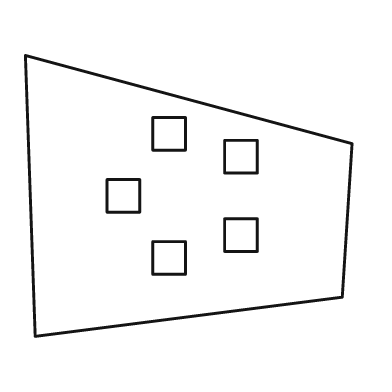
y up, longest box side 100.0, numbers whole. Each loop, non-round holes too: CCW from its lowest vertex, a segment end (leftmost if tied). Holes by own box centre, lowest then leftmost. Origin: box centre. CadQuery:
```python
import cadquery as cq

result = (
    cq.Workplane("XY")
    .moveTo(-47.0, -43.0)
    .lineTo(47.0, -31.0)
    .lineTo(50.0, 16.0)
    .lineTo(-50.0, 43.0)
    .close()
    .moveTo(-11.0, -24.0)
    .lineTo(-1.0, -24.0)
    .lineTo(-1.0, -14.0)
    .lineTo(-11.0, -14.0)
    .close()
    .moveTo(11.0, -17.0)
    .lineTo(21.0, -17.0)
    .lineTo(21.0, -7.0)
    .lineTo(11.0, -7.0)
    .close()
    .moveTo(-25.0, -5.0)
    .lineTo(-15.0, -5.0)
    .lineTo(-15.0, 5.0)
    .lineTo(-25.0, 5.0)
    .close()
    .moveTo(11.0, 7.0)
    .lineTo(21.0, 7.0)
    .lineTo(21.0, 17.0)
    .lineTo(11.0, 17.0)
    .close()
    .moveTo(-11.0, 14.0)
    .lineTo(-1.0, 14.0)
    .lineTo(-1.0, 24.0)
    .lineTo(-11.0, 24.0)
    .close()
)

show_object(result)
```